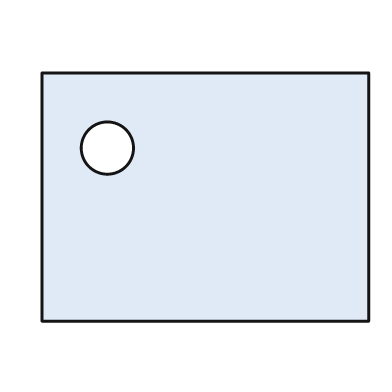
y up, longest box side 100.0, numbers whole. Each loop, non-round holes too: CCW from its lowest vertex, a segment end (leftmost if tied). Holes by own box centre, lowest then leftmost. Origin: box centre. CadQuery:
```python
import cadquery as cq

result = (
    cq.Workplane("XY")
    .moveTo(-50.0, -38.0)
    .lineTo(50.0, -38.0)
    .lineTo(50.0, 38.0)
    .lineTo(-50.0, 38.0)
    .close()
    .moveTo(-30.0, 15.0)
    .circle(8.0)
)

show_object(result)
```